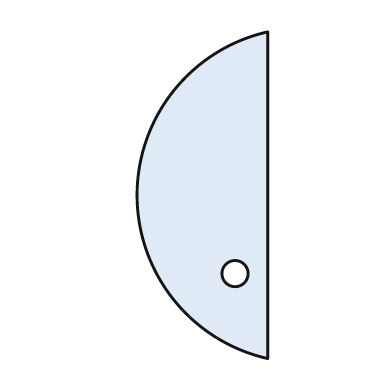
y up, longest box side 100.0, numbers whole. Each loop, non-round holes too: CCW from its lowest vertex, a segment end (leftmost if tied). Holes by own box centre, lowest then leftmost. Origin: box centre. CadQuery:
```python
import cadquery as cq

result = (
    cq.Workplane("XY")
    .moveTo(20.0, -50.0)
    .lineTo(20.0, 50.0)
    .threePointArc((-20.0, 0.0), (20.0, -50.0))
    .close()
    .moveTo(10.0, -24.0)
    .circle(4.0)
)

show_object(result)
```